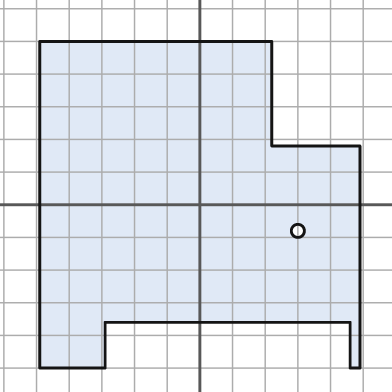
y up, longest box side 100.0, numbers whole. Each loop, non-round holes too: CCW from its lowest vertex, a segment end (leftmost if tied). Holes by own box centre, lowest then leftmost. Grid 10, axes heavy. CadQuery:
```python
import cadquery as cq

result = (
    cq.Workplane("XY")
    .moveTo(-49.0, -50.0)
    .lineTo(-29.0, -50.0)
    .lineTo(-29.0, -36.0)
    .lineTo(46.0, -36.0)
    .lineTo(46.0, -50.0)
    .lineTo(49.0, -50.0)
    .lineTo(49.0, 18.0)
    .lineTo(22.0, 18.0)
    .lineTo(22.0, 50.0)
    .lineTo(-49.0, 50.0)
    .close()
    .moveTo(30.0, -8.0)
    .circle(2.0)
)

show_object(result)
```